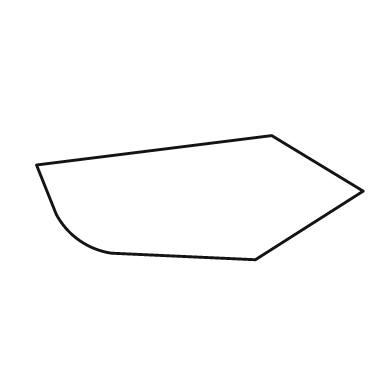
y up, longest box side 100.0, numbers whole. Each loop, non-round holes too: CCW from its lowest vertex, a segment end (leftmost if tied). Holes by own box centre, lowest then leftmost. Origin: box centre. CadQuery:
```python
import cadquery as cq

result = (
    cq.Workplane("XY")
    .moveTo(17.0, -19.0)
    .lineTo(50.0, 2.0)
    .lineTo(22.0, 19.0)
    .lineTo(-50.0, 10.0)
    .lineTo(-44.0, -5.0)
    .threePointArc((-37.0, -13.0), (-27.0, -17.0))
    .close()
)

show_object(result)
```